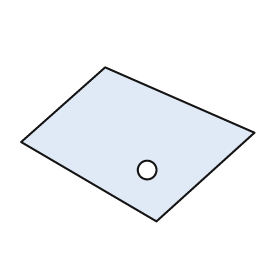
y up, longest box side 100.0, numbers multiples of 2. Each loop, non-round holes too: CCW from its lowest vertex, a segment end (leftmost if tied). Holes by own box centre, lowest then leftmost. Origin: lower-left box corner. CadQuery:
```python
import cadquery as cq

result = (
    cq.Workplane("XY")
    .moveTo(58.0, 0.0)
    .lineTo(100.0, 38.0)
    .lineTo(36.0, 66.0)
    .lineTo(0.0, 34.0)
    .close()
    .moveTo(54.0, 22.0)
    .circle(4.0)
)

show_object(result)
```